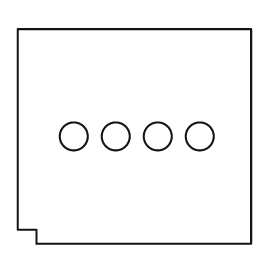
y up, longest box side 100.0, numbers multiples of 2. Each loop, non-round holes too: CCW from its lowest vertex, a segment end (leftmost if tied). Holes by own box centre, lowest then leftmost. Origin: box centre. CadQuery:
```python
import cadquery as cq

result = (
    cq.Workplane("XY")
    .moveTo(-42.0, -46.0)
    .lineTo(50.0, -46.0)
    .lineTo(50.0, 46.0)
    .lineTo(-50.0, 46.0)
    .lineTo(-50.0, -40.0)
    .lineTo(-42.0, -40.0)
    .close()
    .moveTo(-26.0, 0.0)
    .circle(6.0)
    .moveTo(-8.0, 0.0)
    .circle(6.0)
    .moveTo(10.0, 0.0)
    .circle(6.0)
    .moveTo(28.0, 0.0)
    .circle(6.0)
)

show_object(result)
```